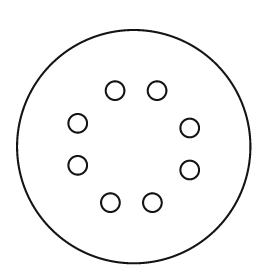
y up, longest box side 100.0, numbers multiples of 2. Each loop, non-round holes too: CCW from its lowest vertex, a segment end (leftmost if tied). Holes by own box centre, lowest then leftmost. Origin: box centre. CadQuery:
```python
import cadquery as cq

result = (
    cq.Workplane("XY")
    .moveTo(0.0, 0.0)
    .circle(50.0)
    .moveTo(-10.0, -24.0)
    .circle(4.0)
    .moveTo(8.0, -24.0)
    .circle(4.0)
    .moveTo(24.0, -10.0)
    .circle(4.0)
    .moveTo(-24.0, -8.0)
    .circle(4.0)
    .moveTo(24.0, 8.0)
    .circle(4.0)
    .moveTo(-24.0, 10.0)
    .circle(4.0)
    .moveTo(-8.0, 24.0)
    .circle(4.0)
    .moveTo(10.0, 24.0)
    .circle(4.0)
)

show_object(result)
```